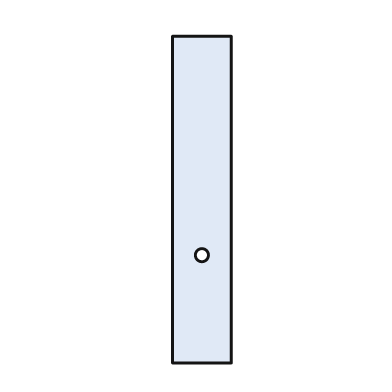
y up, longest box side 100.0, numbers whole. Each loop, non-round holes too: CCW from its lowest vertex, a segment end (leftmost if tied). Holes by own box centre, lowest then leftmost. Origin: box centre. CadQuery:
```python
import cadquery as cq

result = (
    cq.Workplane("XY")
    .moveTo(-9.0, -50.0)
    .lineTo(9.0, -50.0)
    .lineTo(9.0, 50.0)
    .lineTo(-9.0, 50.0)
    .close()
    .moveTo(0.0, -17.0)
    .circle(2.0)
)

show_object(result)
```